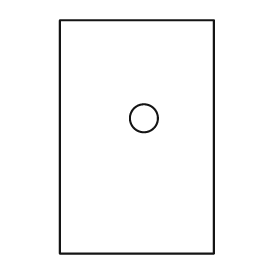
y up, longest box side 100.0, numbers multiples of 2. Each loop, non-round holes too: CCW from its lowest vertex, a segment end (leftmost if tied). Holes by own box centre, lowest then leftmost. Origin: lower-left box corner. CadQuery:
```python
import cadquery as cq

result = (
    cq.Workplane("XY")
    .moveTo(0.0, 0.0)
    .lineTo(66.0, 0.0)
    .lineTo(66.0, 100.0)
    .lineTo(0.0, 100.0)
    .close()
    .moveTo(36.0, 58.0)
    .circle(6.0)
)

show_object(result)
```